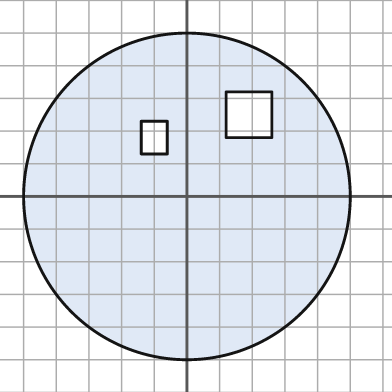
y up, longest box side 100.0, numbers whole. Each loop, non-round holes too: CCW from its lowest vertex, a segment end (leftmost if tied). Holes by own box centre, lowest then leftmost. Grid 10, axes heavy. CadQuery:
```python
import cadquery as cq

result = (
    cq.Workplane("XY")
    .moveTo(0.0, 0.0)
    .circle(50.0)
    .moveTo(-14.0, 13.0)
    .lineTo(-6.0, 13.0)
    .lineTo(-6.0, 23.0)
    .lineTo(-14.0, 23.0)
    .close()
    .moveTo(12.0, 18.0)
    .lineTo(26.0, 18.0)
    .lineTo(26.0, 32.0)
    .lineTo(12.0, 32.0)
    .close()
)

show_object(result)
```